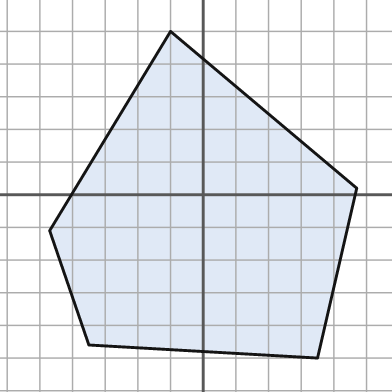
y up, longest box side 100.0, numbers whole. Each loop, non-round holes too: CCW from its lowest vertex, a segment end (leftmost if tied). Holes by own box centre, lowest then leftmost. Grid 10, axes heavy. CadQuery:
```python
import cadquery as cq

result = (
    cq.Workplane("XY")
    .moveTo(35.0, -50.0)
    .lineTo(47.0, 2.0)
    .lineTo(-10.0, 50.0)
    .lineTo(-47.0, -11.0)
    .lineTo(-35.0, -46.0)
    .close()
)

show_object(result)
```